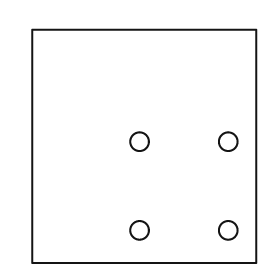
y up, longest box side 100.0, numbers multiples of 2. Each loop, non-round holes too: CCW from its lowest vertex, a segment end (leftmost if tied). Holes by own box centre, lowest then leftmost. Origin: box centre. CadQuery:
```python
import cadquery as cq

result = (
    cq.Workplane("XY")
    .moveTo(-48.0, -50.0)
    .lineTo(48.0, -50.0)
    .lineTo(48.0, 50.0)
    .lineTo(-48.0, 50.0)
    .close()
    .moveTo(-2.0, -36.0)
    .circle(4.0)
    .moveTo(36.0, -36.0)
    .circle(4.0)
    .moveTo(-2.0, 2.0)
    .circle(4.0)
    .moveTo(36.0, 2.0)
    .circle(4.0)
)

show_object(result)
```